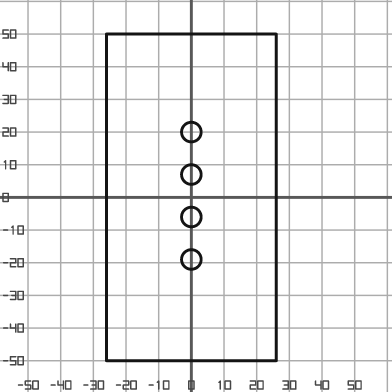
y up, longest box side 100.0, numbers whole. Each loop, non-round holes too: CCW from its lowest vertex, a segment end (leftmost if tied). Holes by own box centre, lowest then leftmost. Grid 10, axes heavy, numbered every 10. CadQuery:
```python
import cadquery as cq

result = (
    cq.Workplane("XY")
    .moveTo(-26.0, -50.0)
    .lineTo(26.0, -50.0)
    .lineTo(26.0, 50.0)
    .lineTo(-26.0, 50.0)
    .close()
    .moveTo(0.0, -19.0)
    .circle(3.0)
    .moveTo(0.0, -6.0)
    .circle(3.0)
    .moveTo(0.0, 7.0)
    .circle(3.0)
    .moveTo(0.0, 20.0)
    .circle(3.0)
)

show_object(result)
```